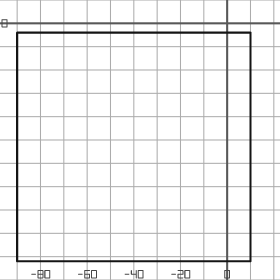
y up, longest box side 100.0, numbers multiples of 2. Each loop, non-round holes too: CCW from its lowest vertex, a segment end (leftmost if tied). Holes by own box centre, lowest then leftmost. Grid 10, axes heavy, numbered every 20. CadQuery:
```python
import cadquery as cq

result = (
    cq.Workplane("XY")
    .moveTo(-90.0, -102.0)
    .lineTo(10.0, -102.0)
    .lineTo(10.0, -4.0)
    .lineTo(-90.0, -4.0)
    .close()
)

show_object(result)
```